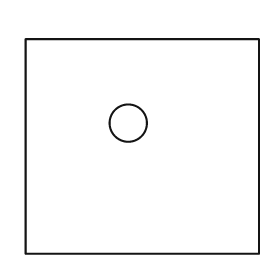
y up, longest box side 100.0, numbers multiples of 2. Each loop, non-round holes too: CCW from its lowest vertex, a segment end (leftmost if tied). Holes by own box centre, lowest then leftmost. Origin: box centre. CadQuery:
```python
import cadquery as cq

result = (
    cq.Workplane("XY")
    .moveTo(-50.0, -46.0)
    .lineTo(50.0, -46.0)
    .lineTo(50.0, 46.0)
    .lineTo(-50.0, 46.0)
    .close()
    .moveTo(-6.0, 10.0)
    .circle(8.0)
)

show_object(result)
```